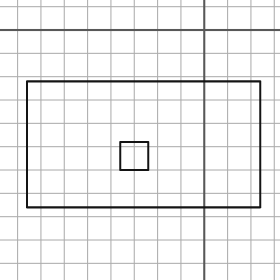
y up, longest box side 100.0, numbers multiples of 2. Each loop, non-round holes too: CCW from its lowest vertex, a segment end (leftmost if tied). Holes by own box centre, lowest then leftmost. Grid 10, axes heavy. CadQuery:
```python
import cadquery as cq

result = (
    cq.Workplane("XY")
    .moveTo(-76.0, -76.0)
    .lineTo(24.0, -76.0)
    .lineTo(24.0, -22.0)
    .lineTo(-76.0, -22.0)
    .close()
    .moveTo(-36.0, -60.0)
    .lineTo(-24.0, -60.0)
    .lineTo(-24.0, -48.0)
    .lineTo(-36.0, -48.0)
    .close()
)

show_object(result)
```